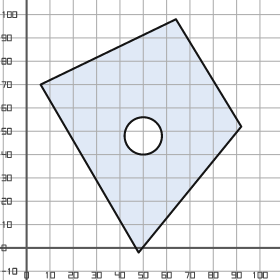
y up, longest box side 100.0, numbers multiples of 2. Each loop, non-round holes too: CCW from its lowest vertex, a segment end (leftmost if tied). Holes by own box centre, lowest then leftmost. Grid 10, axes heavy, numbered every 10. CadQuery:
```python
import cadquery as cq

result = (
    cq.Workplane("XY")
    .moveTo(48.0, -2.0)
    .lineTo(92.0, 52.0)
    .lineTo(64.0, 98.0)
    .lineTo(6.0, 70.0)
    .close()
    .moveTo(50.0, 48.0)
    .circle(8.0)
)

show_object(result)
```